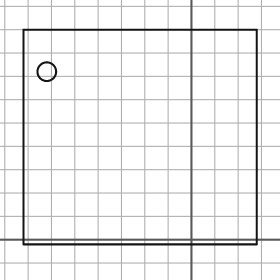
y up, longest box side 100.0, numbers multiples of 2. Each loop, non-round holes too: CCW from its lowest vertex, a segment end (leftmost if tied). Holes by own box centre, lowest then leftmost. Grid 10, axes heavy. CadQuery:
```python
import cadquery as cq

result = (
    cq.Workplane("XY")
    .moveTo(-72.0, -2.0)
    .lineTo(28.0, -2.0)
    .lineTo(28.0, 90.0)
    .lineTo(-72.0, 90.0)
    .close()
    .moveTo(-62.0, 72.0)
    .circle(4.0)
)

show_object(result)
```